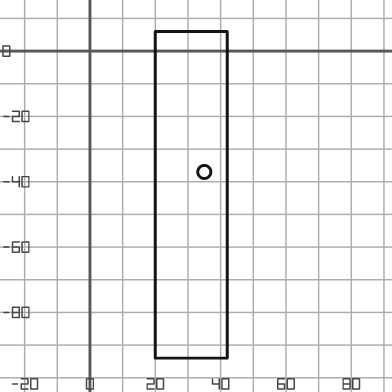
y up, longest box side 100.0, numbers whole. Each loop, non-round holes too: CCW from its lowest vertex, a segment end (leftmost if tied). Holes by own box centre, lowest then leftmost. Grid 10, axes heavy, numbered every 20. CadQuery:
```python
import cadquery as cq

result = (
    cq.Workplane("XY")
    .moveTo(20.0, -94.0)
    .lineTo(42.0, -94.0)
    .lineTo(42.0, 6.0)
    .lineTo(20.0, 6.0)
    .close()
    .moveTo(35.0, -37.0)
    .circle(2.0)
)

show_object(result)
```